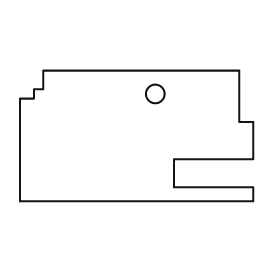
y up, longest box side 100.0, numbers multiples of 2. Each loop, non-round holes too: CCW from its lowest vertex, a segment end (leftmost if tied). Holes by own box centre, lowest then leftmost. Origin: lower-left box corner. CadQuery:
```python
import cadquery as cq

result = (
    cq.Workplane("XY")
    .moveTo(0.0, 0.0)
    .lineTo(100.0, 0.0)
    .lineTo(100.0, 6.0)
    .lineTo(66.0, 6.0)
    .lineTo(66.0, 18.0)
    .lineTo(100.0, 18.0)
    .lineTo(100.0, 34.0)
    .lineTo(94.0, 34.0)
    .lineTo(94.0, 56.0)
    .lineTo(10.0, 56.0)
    .lineTo(10.0, 48.0)
    .lineTo(6.0, 48.0)
    .lineTo(6.0, 44.0)
    .lineTo(0.0, 44.0)
    .close()
    .moveTo(58.0, 46.0)
    .circle(4.0)
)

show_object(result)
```